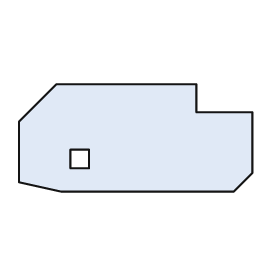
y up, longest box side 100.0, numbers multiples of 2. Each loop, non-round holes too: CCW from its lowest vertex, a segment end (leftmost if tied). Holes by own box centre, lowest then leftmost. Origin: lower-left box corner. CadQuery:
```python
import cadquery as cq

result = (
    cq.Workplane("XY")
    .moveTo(18.0, 0.0)
    .lineTo(92.0, 0.0)
    .lineTo(100.0, 8.0)
    .lineTo(100.0, 34.0)
    .lineTo(76.0, 34.0)
    .lineTo(76.0, 46.0)
    .lineTo(16.0, 46.0)
    .lineTo(0.0, 30.0)
    .lineTo(0.0, 4.0)
    .close()
    .moveTo(22.0, 10.0)
    .lineTo(30.0, 10.0)
    .lineTo(30.0, 18.0)
    .lineTo(22.0, 18.0)
    .close()
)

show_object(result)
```